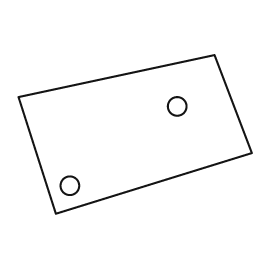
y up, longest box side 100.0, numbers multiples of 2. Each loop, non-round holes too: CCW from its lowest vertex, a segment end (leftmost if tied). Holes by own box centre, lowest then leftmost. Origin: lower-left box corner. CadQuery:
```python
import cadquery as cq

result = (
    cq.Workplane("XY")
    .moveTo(16.0, 0.0)
    .lineTo(100.0, 26.0)
    .lineTo(84.0, 68.0)
    .lineTo(0.0, 50.0)
    .close()
    .moveTo(22.0, 12.0)
    .circle(4.0)
    .moveTo(68.0, 46.0)
    .circle(4.0)
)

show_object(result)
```